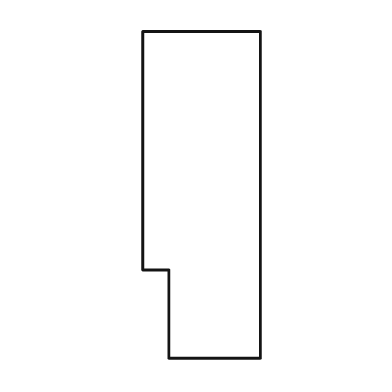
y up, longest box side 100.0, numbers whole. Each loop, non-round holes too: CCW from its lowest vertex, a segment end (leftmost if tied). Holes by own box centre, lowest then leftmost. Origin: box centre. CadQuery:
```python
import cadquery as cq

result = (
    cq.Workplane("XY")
    .moveTo(-10.0, -50.0)
    .lineTo(18.0, -50.0)
    .lineTo(18.0, 50.0)
    .lineTo(-18.0, 50.0)
    .lineTo(-18.0, -23.0)
    .lineTo(-10.0, -23.0)
    .close()
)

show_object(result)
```